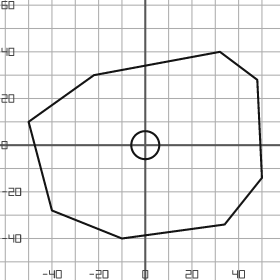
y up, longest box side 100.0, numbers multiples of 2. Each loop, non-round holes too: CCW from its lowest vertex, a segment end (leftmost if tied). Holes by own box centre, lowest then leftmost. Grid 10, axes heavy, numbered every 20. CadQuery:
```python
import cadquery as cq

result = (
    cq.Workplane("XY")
    .moveTo(-10.0, -40.0)
    .lineTo(34.0, -34.0)
    .lineTo(50.0, -14.0)
    .lineTo(48.0, 28.0)
    .lineTo(32.0, 40.0)
    .lineTo(-22.0, 30.0)
    .lineTo(-50.0, 10.0)
    .lineTo(-40.0, -28.0)
    .close()
    .moveTo(0.0, 0.0)
    .circle(6.0)
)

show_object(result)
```